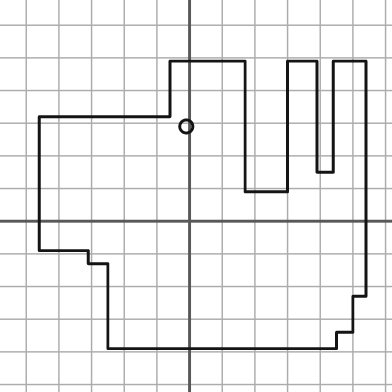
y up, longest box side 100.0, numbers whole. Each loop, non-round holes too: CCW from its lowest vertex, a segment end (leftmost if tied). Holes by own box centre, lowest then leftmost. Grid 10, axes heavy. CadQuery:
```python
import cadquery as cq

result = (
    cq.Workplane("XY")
    .moveTo(-25.0, -39.0)
    .lineTo(45.0, -39.0)
    .lineTo(45.0, -34.0)
    .lineTo(50.0, -34.0)
    .lineTo(50.0, -23.0)
    .lineTo(54.0, -23.0)
    .lineTo(54.0, 49.0)
    .lineTo(44.0, 49.0)
    .lineTo(44.0, 15.0)
    .lineTo(39.0, 15.0)
    .lineTo(39.0, 49.0)
    .lineTo(30.0, 49.0)
    .lineTo(30.0, 9.0)
    .lineTo(17.0, 9.0)
    .lineTo(17.0, 49.0)
    .lineTo(-6.0, 49.0)
    .lineTo(-6.0, 32.0)
    .lineTo(-46.0, 32.0)
    .lineTo(-46.0, -9.0)
    .lineTo(-31.0, -9.0)
    .lineTo(-31.0, -13.0)
    .lineTo(-25.0, -13.0)
    .close()
    .moveTo(-1.0, 29.0)
    .circle(2.0)
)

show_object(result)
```